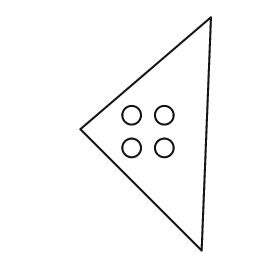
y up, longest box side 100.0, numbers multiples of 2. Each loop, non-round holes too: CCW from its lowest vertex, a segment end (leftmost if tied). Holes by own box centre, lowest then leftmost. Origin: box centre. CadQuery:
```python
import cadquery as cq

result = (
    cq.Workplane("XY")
    .moveTo(24.0, -50.0)
    .lineTo(28.0, 50.0)
    .lineTo(-28.0, 2.0)
    .close()
    .moveTo(-6.0, -6.0)
    .circle(4.0)
    .moveTo(8.0, -6.0)
    .circle(4.0)
    .moveTo(-6.0, 8.0)
    .circle(4.0)
    .moveTo(8.0, 8.0)
    .circle(4.0)
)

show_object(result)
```